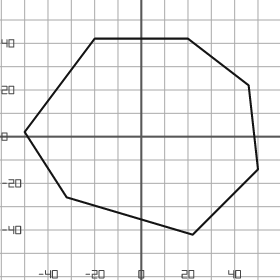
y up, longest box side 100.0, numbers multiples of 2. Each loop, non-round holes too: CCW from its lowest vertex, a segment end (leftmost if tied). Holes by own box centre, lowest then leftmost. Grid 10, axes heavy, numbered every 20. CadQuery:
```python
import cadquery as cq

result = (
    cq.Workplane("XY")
    .moveTo(22.0, -42.0)
    .lineTo(50.0, -14.0)
    .lineTo(46.0, 22.0)
    .lineTo(20.0, 42.0)
    .lineTo(-20.0, 42.0)
    .lineTo(-50.0, 2.0)
    .lineTo(-32.0, -26.0)
    .close()
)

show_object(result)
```